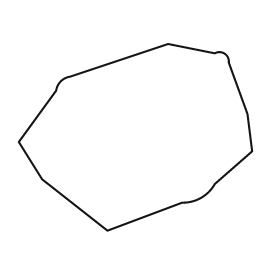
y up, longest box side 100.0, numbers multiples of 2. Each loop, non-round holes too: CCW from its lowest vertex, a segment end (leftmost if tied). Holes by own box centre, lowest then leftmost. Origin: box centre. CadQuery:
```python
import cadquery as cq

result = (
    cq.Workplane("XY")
    .moveTo(-12.0, -40.0)
    .lineTo(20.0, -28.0)
    .threePointArc((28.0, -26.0), (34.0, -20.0))
    .lineTo(50.0, -6.0)
    .lineTo(48.0, 10.0)
    .lineTo(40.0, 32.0)
    .threePointArc((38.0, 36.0), (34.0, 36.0))
    .lineTo(14.0, 40.0)
    .lineTo(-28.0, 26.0)
    .threePointArc((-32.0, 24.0), (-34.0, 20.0))
    .lineTo(-50.0, -2.0)
    .lineTo(-40.0, -18.0)
    .close()
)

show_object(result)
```